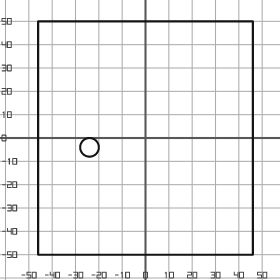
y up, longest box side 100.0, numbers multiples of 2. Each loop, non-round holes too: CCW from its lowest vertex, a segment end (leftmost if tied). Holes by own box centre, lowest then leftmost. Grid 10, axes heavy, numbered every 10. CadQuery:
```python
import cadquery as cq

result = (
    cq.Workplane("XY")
    .moveTo(-46.0, -50.0)
    .lineTo(46.0, -50.0)
    .lineTo(46.0, 50.0)
    .lineTo(-46.0, 50.0)
    .close()
    .moveTo(-24.0, -4.0)
    .circle(4.0)
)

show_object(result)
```